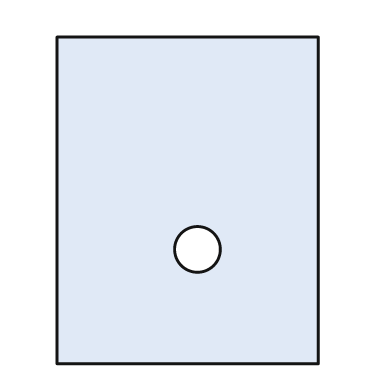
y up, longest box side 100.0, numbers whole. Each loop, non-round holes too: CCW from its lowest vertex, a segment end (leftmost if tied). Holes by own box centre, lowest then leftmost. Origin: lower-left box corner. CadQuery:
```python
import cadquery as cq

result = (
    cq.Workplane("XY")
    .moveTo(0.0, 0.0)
    .lineTo(80.0, 0.0)
    .lineTo(80.0, 100.0)
    .lineTo(0.0, 100.0)
    .close()
    .moveTo(43.0, 35.0)
    .circle(7.0)
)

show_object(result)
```